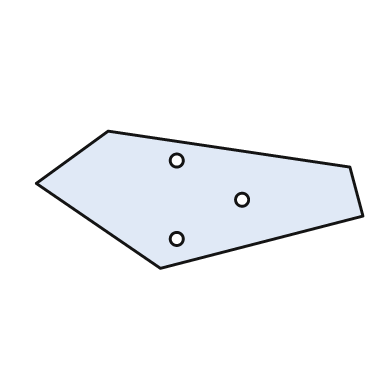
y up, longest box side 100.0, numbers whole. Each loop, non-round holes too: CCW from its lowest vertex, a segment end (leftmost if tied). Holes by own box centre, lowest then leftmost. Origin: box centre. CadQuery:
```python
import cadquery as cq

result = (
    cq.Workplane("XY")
    .moveTo(-12.0, -21.0)
    .lineTo(50.0, -5.0)
    .lineTo(46.0, 10.0)
    .lineTo(-28.0, 21.0)
    .lineTo(-50.0, 5.0)
    .close()
    .moveTo(-7.0, -12.0)
    .circle(2.0)
    .moveTo(13.0, 0.0)
    .circle(2.0)
    .moveTo(-7.0, 12.0)
    .circle(2.0)
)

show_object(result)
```